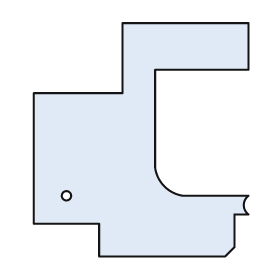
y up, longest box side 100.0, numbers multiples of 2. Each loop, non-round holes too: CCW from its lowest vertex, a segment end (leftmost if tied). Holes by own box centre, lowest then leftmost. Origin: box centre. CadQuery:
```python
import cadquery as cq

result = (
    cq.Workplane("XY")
    .moveTo(-18.0, -50.0)
    .lineTo(36.0, -50.0)
    .lineTo(40.0, -46.0)
    .lineTo(40.0, -32.0)
    .lineTo(46.0, -32.0)
    .threePointArc((44.0, -28.0), (46.0, -24.0))
    .lineTo(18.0, -24.0)
    .threePointArc((10.0, -20.0), (6.0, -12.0))
    .lineTo(6.0, 30.0)
    .lineTo(46.0, 30.0)
    .lineTo(46.0, 50.0)
    .lineTo(-8.0, 50.0)
    .lineTo(-8.0, 20.0)
    .lineTo(-46.0, 20.0)
    .lineTo(-46.0, -36.0)
    .lineTo(-18.0, -36.0)
    .close()
    .moveTo(-32.0, -24.0)
    .circle(2.0)
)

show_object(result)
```